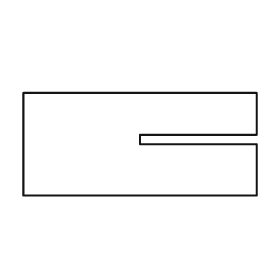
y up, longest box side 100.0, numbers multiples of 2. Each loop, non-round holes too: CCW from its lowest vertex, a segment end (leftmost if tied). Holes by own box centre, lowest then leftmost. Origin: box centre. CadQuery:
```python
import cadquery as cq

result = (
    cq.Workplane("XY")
    .moveTo(-50.0, -22.0)
    .lineTo(50.0, -22.0)
    .lineTo(50.0, 0.0)
    .lineTo(0.0, 0.0)
    .lineTo(0.0, 4.0)
    .lineTo(50.0, 4.0)
    .lineTo(50.0, 22.0)
    .lineTo(-50.0, 22.0)
    .close()
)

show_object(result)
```